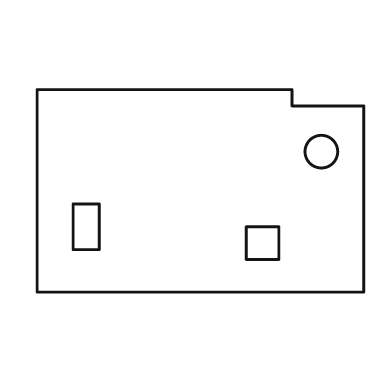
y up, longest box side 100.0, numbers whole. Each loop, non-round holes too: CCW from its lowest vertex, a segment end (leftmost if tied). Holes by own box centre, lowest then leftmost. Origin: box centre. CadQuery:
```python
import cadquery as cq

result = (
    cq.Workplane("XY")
    .moveTo(-50.0, -31.0)
    .lineTo(50.0, -31.0)
    .lineTo(50.0, 26.0)
    .lineTo(28.0, 26.0)
    .lineTo(28.0, 31.0)
    .lineTo(-50.0, 31.0)
    .close()
    .moveTo(14.0, -21.0)
    .lineTo(24.0, -21.0)
    .lineTo(24.0, -11.0)
    .lineTo(14.0, -11.0)
    .close()
    .moveTo(-39.0, -18.0)
    .lineTo(-31.0, -18.0)
    .lineTo(-31.0, -4.0)
    .lineTo(-39.0, -4.0)
    .close()
    .moveTo(37.0, 12.0)
    .circle(5.0)
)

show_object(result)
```